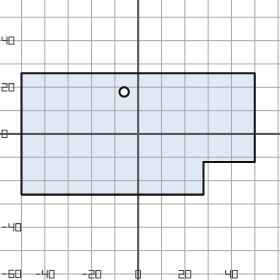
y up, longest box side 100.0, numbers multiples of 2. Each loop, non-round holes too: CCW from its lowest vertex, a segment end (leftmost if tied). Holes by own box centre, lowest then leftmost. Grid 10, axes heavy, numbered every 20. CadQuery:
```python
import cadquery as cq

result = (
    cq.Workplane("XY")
    .moveTo(-50.0, -26.0)
    .lineTo(28.0, -26.0)
    .lineTo(28.0, -12.0)
    .lineTo(50.0, -12.0)
    .lineTo(50.0, 26.0)
    .lineTo(-50.0, 26.0)
    .close()
    .moveTo(-6.0, 18.0)
    .circle(2.0)
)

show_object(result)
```